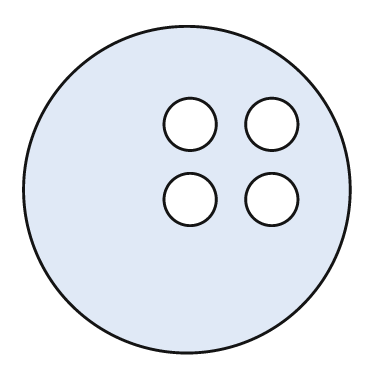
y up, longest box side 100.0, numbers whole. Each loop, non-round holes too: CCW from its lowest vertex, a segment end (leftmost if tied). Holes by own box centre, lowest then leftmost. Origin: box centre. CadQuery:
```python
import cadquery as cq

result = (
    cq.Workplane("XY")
    .moveTo(0.0, 0.0)
    .circle(50.0)
    .moveTo(1.0, -3.0)
    .circle(8.0)
    .moveTo(26.0, -3.0)
    .circle(8.0)
    .moveTo(1.0, 20.0)
    .circle(8.0)
    .moveTo(26.0, 20.0)
    .circle(8.0)
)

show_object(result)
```